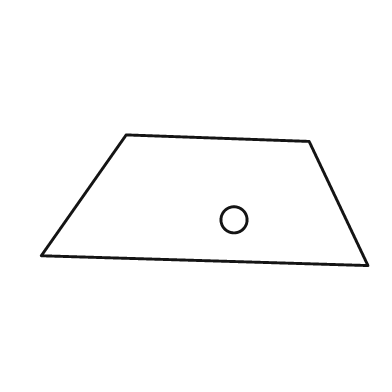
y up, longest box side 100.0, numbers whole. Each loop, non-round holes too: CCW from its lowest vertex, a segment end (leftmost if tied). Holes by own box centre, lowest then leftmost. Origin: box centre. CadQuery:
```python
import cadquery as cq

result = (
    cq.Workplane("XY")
    .moveTo(50.0, -20.0)
    .lineTo(32.0, 18.0)
    .lineTo(-24.0, 20.0)
    .lineTo(-50.0, -17.0)
    .close()
    .moveTo(9.0, -6.0)
    .circle(4.0)
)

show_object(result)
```